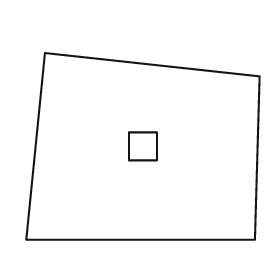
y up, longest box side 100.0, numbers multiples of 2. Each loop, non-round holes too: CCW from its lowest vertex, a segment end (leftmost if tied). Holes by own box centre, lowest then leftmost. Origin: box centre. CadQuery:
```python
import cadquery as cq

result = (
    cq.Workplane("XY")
    .moveTo(-50.0, -40.0)
    .lineTo(48.0, -40.0)
    .lineTo(50.0, 30.0)
    .lineTo(-42.0, 40.0)
    .close()
    .moveTo(-6.0, -6.0)
    .lineTo(6.0, -6.0)
    .lineTo(6.0, 6.0)
    .lineTo(-6.0, 6.0)
    .close()
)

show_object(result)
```